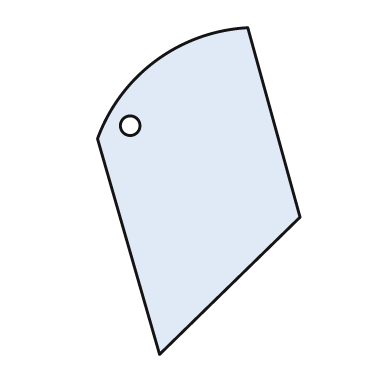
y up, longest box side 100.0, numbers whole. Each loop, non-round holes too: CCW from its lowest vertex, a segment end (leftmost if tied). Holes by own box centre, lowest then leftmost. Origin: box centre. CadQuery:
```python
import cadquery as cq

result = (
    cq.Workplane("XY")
    .moveTo(-12.0, -50.0)
    .lineTo(31.0, -8.0)
    .lineTo(15.0, 50.0)
    .threePointArc((-13.0, 40.0), (-31.0, 16.0))
    .close()
    .moveTo(-21.0, 20.0)
    .circle(3.0)
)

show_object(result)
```